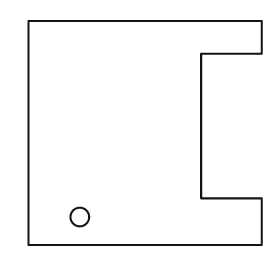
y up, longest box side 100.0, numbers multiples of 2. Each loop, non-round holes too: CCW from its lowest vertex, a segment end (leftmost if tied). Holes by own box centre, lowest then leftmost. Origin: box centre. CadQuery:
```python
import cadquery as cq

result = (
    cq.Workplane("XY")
    .moveTo(-50.0, -48.0)
    .lineTo(50.0, -48.0)
    .lineTo(50.0, -28.0)
    .lineTo(24.0, -28.0)
    .lineTo(24.0, 34.0)
    .lineTo(50.0, 34.0)
    .lineTo(50.0, 48.0)
    .lineTo(-50.0, 48.0)
    .close()
    .moveTo(-28.0, -36.0)
    .circle(4.0)
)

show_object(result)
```